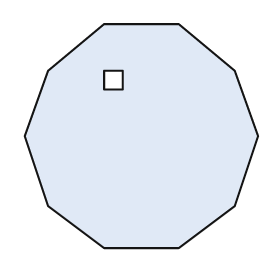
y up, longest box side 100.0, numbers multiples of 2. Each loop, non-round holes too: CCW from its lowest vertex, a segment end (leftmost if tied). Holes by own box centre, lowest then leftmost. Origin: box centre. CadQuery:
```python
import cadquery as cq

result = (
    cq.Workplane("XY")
    .moveTo(-16.0, -48.0)
    .lineTo(16.0, -48.0)
    .lineTo(40.0, -30.0)
    .lineTo(50.0, 0.0)
    .lineTo(40.0, 28.0)
    .lineTo(16.0, 48.0)
    .lineTo(-16.0, 48.0)
    .lineTo(-40.0, 28.0)
    .lineTo(-50.0, 0.0)
    .lineTo(-40.0, -30.0)
    .close()
    .moveTo(-16.0, 20.0)
    .lineTo(-8.0, 20.0)
    .lineTo(-8.0, 28.0)
    .lineTo(-16.0, 28.0)
    .close()
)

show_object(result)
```